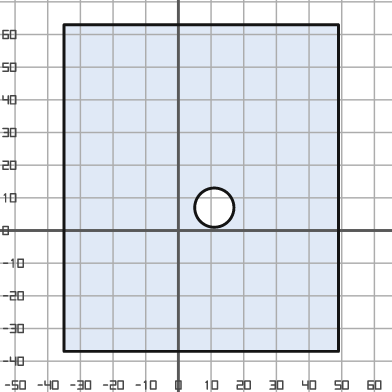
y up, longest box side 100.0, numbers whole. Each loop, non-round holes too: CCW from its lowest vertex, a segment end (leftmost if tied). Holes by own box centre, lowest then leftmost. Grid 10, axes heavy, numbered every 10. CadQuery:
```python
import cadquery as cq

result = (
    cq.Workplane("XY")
    .moveTo(-35.0, -37.0)
    .lineTo(49.0, -37.0)
    .lineTo(49.0, 63.0)
    .lineTo(-35.0, 63.0)
    .close()
    .moveTo(11.0, 7.0)
    .circle(6.0)
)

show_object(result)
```